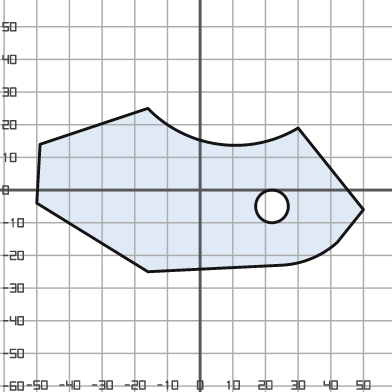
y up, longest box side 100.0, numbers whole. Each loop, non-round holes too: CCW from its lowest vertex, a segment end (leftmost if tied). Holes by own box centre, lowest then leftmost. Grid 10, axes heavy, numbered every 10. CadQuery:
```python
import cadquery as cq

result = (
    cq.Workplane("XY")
    .moveTo(-16.0, -25.0)
    .lineTo(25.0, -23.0)
    .threePointArc((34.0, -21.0), (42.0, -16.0))
    .lineTo(50.0, -6.0)
    .lineTo(30.0, 19.0)
    .threePointArc((6.0, 14.0), (-16.0, 25.0))
    .lineTo(-49.0, 14.0)
    .lineTo(-50.0, -4.0)
    .close()
    .moveTo(22.0, -5.0)
    .circle(5.0)
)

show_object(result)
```